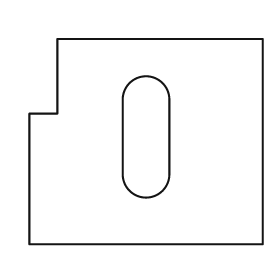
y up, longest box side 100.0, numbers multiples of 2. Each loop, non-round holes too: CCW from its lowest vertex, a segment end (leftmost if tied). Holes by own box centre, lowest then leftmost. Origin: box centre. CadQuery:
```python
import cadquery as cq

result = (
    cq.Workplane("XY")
    .moveTo(-50.0, -44.0)
    .lineTo(50.0, -44.0)
    .lineTo(50.0, 44.0)
    .lineTo(-38.0, 44.0)
    .lineTo(-38.0, 12.0)
    .lineTo(-50.0, 12.0)
    .close()
    .moveTo(-10.0, -14.0)
    .threePointArc((0.0, -24.0), (10.0, -14.0))
    .lineTo(10.0, 18.0)
    .threePointArc((0.0, 28.0), (-10.0, 18.0))
    .close()
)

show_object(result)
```